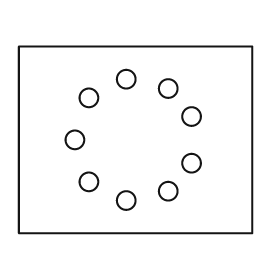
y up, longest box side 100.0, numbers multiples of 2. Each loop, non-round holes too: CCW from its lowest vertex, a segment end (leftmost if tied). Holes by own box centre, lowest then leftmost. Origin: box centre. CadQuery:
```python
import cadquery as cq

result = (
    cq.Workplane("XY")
    .moveTo(-50.0, -40.0)
    .lineTo(50.0, -40.0)
    .lineTo(50.0, 40.0)
    .lineTo(-50.0, 40.0)
    .close()
    .moveTo(-4.0, -26.0)
    .circle(4.0)
    .moveTo(14.0, -22.0)
    .circle(4.0)
    .moveTo(-20.0, -18.0)
    .circle(4.0)
    .moveTo(24.0, -10.0)
    .circle(4.0)
    .moveTo(-26.0, 0.0)
    .circle(4.0)
    .moveTo(24.0, 10.0)
    .circle(4.0)
    .moveTo(-20.0, 18.0)
    .circle(4.0)
    .moveTo(14.0, 22.0)
    .circle(4.0)
    .moveTo(-4.0, 26.0)
    .circle(4.0)
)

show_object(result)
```